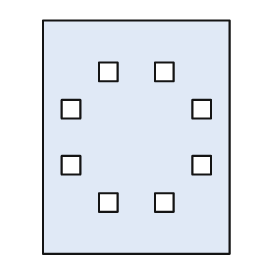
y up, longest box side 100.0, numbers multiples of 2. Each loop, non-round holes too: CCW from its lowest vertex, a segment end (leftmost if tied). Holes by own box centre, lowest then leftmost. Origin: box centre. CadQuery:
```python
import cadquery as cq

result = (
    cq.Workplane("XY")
    .moveTo(-40.0, -50.0)
    .lineTo(40.0, -50.0)
    .lineTo(40.0, 50.0)
    .lineTo(-40.0, 50.0)
    .close()
    .moveTo(-16.0, -32.0)
    .lineTo(-8.0, -32.0)
    .lineTo(-8.0, -24.0)
    .lineTo(-16.0, -24.0)
    .close()
    .moveTo(8.0, -32.0)
    .lineTo(16.0, -32.0)
    .lineTo(16.0, -24.0)
    .lineTo(8.0, -24.0)
    .close()
    .moveTo(-32.0, -16.0)
    .lineTo(-24.0, -16.0)
    .lineTo(-24.0, -8.0)
    .lineTo(-32.0, -8.0)
    .close()
    .moveTo(24.0, -16.0)
    .lineTo(32.0, -16.0)
    .lineTo(32.0, -8.0)
    .lineTo(24.0, -8.0)
    .close()
    .moveTo(-32.0, 8.0)
    .lineTo(-24.0, 8.0)
    .lineTo(-24.0, 16.0)
    .lineTo(-32.0, 16.0)
    .close()
    .moveTo(24.0, 8.0)
    .lineTo(32.0, 8.0)
    .lineTo(32.0, 16.0)
    .lineTo(24.0, 16.0)
    .close()
    .moveTo(-16.0, 24.0)
    .lineTo(-8.0, 24.0)
    .lineTo(-8.0, 32.0)
    .lineTo(-16.0, 32.0)
    .close()
    .moveTo(8.0, 24.0)
    .lineTo(16.0, 24.0)
    .lineTo(16.0, 32.0)
    .lineTo(8.0, 32.0)
    .close()
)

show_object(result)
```